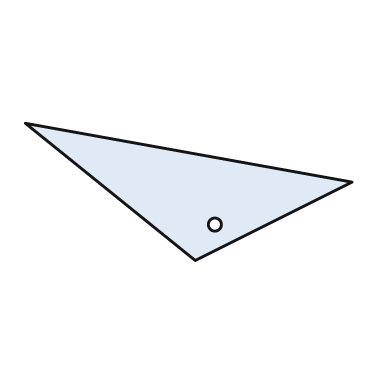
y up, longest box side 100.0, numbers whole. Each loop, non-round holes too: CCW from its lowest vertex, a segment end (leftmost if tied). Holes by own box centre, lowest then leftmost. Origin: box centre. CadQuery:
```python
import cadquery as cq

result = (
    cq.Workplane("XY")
    .moveTo(2.0, -21.0)
    .lineTo(50.0, 3.0)
    .lineTo(-50.0, 21.0)
    .close()
    .moveTo(8.0, -10.0)
    .circle(2.0)
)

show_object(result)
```